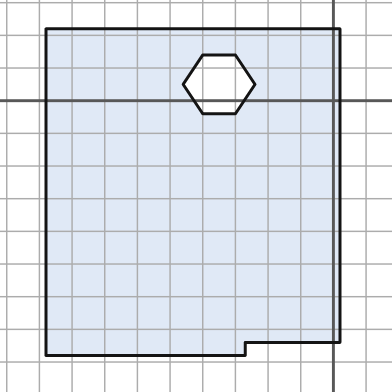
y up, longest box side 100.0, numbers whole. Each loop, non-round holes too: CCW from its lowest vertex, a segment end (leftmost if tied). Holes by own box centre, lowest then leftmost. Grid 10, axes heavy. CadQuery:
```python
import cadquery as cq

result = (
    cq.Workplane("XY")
    .moveTo(-88.0, -78.0)
    .lineTo(-27.0, -78.0)
    .lineTo(-27.0, -74.0)
    .lineTo(2.0, -74.0)
    .lineTo(2.0, 22.0)
    .lineTo(-88.0, 22.0)
    .close()
    .moveTo(-40.0, -4.0)
    .lineTo(-30.0, -4.0)
    .lineTo(-24.0, 5.0)
    .lineTo(-30.0, 14.0)
    .lineTo(-40.0, 14.0)
    .lineTo(-46.0, 5.0)
    .close()
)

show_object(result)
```